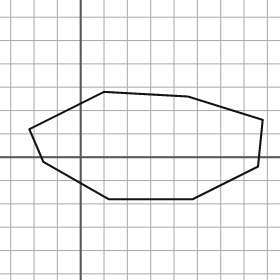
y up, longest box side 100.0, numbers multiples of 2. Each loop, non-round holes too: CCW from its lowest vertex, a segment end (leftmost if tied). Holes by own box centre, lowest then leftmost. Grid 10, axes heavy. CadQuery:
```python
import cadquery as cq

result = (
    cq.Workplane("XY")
    .moveTo(12.0, -18.0)
    .lineTo(48.0, -18.0)
    .lineTo(76.0, -4.0)
    .lineTo(78.0, 16.0)
    .lineTo(46.0, 26.0)
    .lineTo(10.0, 28.0)
    .lineTo(-22.0, 12.0)
    .lineTo(-16.0, -2.0)
    .close()
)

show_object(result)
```